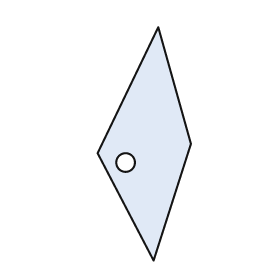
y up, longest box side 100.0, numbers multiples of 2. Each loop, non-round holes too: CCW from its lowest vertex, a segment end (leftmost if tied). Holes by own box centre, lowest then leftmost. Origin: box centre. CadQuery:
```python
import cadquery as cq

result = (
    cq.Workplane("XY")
    .moveTo(4.0, -50.0)
    .lineTo(20.0, 0.0)
    .lineTo(6.0, 50.0)
    .lineTo(-20.0, -4.0)
    .close()
    .moveTo(-8.0, -8.0)
    .circle(4.0)
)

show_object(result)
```